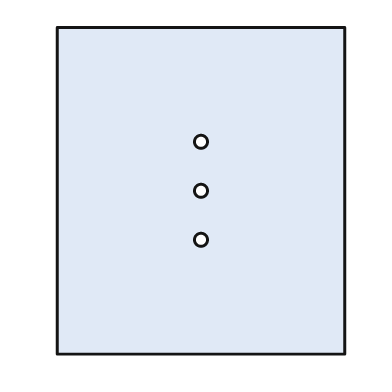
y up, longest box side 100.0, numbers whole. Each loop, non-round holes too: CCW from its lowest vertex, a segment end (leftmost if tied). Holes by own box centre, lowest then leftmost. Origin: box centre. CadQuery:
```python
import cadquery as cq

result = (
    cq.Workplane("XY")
    .moveTo(-44.0, -50.0)
    .lineTo(44.0, -50.0)
    .lineTo(44.0, 50.0)
    .lineTo(-44.0, 50.0)
    .close()
    .moveTo(0.0, -15.0)
    .circle(2.0)
    .moveTo(0.0, 0.0)
    .circle(2.0)
    .moveTo(0.0, 15.0)
    .circle(2.0)
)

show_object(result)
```